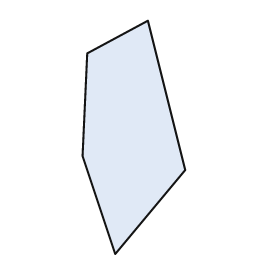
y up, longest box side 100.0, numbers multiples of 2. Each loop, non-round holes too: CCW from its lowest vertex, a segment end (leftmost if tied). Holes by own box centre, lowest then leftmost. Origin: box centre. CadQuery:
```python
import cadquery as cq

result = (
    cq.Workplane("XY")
    .moveTo(-8.0, -50.0)
    .lineTo(22.0, -14.0)
    .lineTo(6.0, 50.0)
    .lineTo(-20.0, 36.0)
    .lineTo(-22.0, -8.0)
    .close()
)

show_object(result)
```